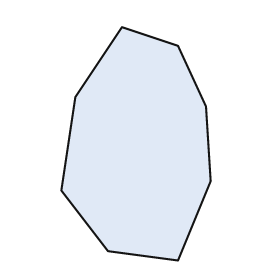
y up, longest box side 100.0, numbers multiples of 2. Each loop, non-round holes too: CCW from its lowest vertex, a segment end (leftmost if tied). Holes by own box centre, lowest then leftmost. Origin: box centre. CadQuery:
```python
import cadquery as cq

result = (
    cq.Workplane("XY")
    .moveTo(18.0, -50.0)
    .lineTo(32.0, -16.0)
    .lineTo(30.0, 16.0)
    .lineTo(18.0, 42.0)
    .lineTo(-6.0, 50.0)
    .lineTo(-26.0, 20.0)
    .lineTo(-32.0, -20.0)
    .lineTo(-12.0, -46.0)
    .close()
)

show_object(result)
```